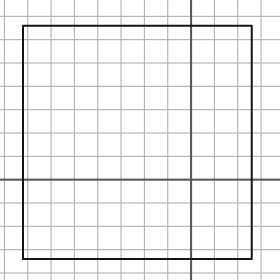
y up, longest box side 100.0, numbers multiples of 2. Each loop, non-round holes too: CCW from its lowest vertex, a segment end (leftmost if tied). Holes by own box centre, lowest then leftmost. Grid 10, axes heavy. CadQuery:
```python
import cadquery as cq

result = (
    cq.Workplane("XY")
    .moveTo(-72.0, -34.0)
    .lineTo(26.0, -34.0)
    .lineTo(26.0, 66.0)
    .lineTo(-72.0, 66.0)
    .close()
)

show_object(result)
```